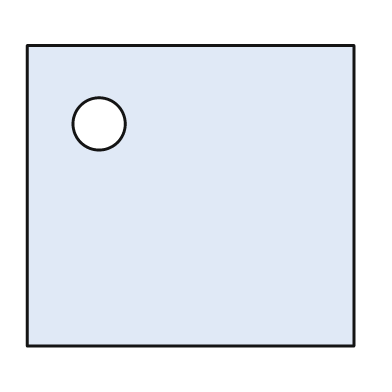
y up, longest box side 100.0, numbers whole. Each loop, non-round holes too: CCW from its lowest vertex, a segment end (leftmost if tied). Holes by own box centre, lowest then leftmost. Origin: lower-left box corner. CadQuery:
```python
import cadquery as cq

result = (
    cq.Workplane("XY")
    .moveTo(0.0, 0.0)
    .lineTo(100.0, 0.0)
    .lineTo(100.0, 92.0)
    .lineTo(0.0, 92.0)
    .close()
    .moveTo(22.0, 68.0)
    .circle(8.0)
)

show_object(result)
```